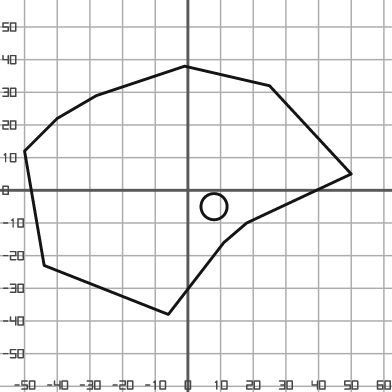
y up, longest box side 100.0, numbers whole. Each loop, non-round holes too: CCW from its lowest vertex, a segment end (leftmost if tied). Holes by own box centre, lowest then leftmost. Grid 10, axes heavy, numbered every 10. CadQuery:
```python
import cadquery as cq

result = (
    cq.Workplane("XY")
    .moveTo(-6.0, -38.0)
    .lineTo(11.0, -16.0)
    .lineTo(18.0, -10.0)
    .lineTo(50.0, 5.0)
    .lineTo(25.0, 32.0)
    .lineTo(-1.0, 38.0)
    .lineTo(-28.0, 29.0)
    .lineTo(-40.0, 22.0)
    .lineTo(-50.0, 12.0)
    .lineTo(-44.0, -23.0)
    .close()
    .moveTo(8.0, -5.0)
    .circle(4.0)
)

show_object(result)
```